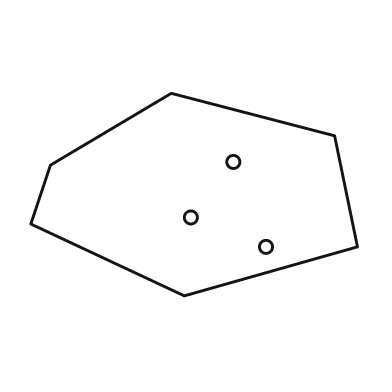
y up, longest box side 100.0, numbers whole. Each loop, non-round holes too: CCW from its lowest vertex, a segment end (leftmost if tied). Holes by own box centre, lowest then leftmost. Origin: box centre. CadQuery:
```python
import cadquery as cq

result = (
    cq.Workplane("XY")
    .moveTo(-3.0, -31.0)
    .lineTo(50.0, -16.0)
    .lineTo(43.0, 18.0)
    .lineTo(-7.0, 31.0)
    .lineTo(-44.0, 9.0)
    .lineTo(-50.0, -9.0)
    .close()
    .moveTo(22.0, -16.0)
    .circle(2.0)
    .moveTo(-1.0, -7.0)
    .circle(2.0)
    .moveTo(12.0, 10.0)
    .circle(2.0)
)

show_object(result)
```